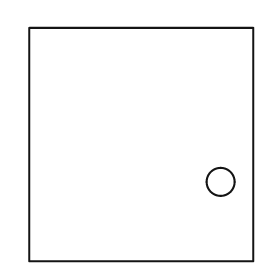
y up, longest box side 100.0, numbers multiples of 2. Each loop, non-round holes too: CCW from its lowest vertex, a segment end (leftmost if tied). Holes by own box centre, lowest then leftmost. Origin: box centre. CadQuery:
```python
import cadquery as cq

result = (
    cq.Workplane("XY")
    .moveTo(-48.0, -50.0)
    .lineTo(48.0, -50.0)
    .lineTo(48.0, 50.0)
    .lineTo(-48.0, 50.0)
    .close()
    .moveTo(34.0, -16.0)
    .circle(6.0)
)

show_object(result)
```